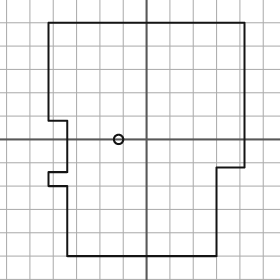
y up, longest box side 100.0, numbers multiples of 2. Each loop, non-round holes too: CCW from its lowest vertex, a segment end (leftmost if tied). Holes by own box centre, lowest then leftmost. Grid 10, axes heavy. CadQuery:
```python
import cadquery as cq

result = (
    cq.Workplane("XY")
    .moveTo(-34.0, -50.0)
    .lineTo(30.0, -50.0)
    .lineTo(30.0, -12.0)
    .lineTo(42.0, -12.0)
    .lineTo(42.0, 50.0)
    .lineTo(-42.0, 50.0)
    .lineTo(-42.0, 8.0)
    .lineTo(-34.0, 8.0)
    .lineTo(-34.0, -14.0)
    .lineTo(-42.0, -14.0)
    .lineTo(-42.0, -20.0)
    .lineTo(-34.0, -20.0)
    .close()
    .moveTo(-12.0, 0.0)
    .circle(2.0)
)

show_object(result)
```